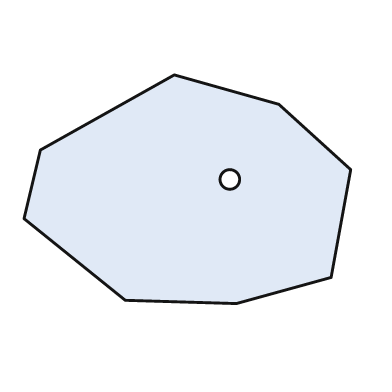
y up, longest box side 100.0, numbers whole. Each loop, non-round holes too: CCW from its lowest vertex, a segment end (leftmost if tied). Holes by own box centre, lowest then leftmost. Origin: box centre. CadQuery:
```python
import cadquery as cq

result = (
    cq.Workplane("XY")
    .moveTo(15.0, -35.0)
    .lineTo(44.0, -27.0)
    .lineTo(50.0, 6.0)
    .lineTo(28.0, 26.0)
    .lineTo(-4.0, 35.0)
    .lineTo(-45.0, 12.0)
    .lineTo(-50.0, -9.0)
    .lineTo(-19.0, -34.0)
    .close()
    .moveTo(13.0, 3.0)
    .circle(3.0)
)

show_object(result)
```